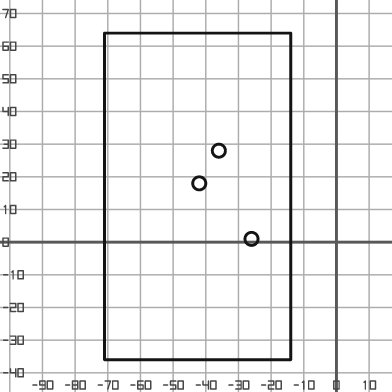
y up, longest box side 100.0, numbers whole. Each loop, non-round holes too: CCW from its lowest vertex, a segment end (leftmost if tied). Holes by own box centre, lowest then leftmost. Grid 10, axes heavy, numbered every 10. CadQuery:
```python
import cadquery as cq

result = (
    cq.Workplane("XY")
    .moveTo(-71.0, -36.0)
    .lineTo(-14.0, -36.0)
    .lineTo(-14.0, 64.0)
    .lineTo(-71.0, 64.0)
    .close()
    .moveTo(-26.0, 1.0)
    .circle(2.0)
    .moveTo(-42.0, 18.0)
    .circle(2.0)
    .moveTo(-36.0, 28.0)
    .circle(2.0)
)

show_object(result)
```